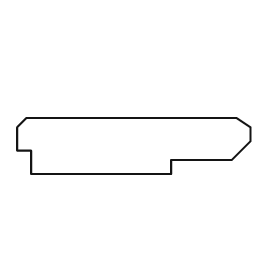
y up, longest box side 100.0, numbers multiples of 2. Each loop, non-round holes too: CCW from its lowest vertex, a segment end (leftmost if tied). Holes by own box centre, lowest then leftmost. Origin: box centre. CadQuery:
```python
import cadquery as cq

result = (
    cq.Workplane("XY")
    .moveTo(-44.0, -12.0)
    .lineTo(16.0, -12.0)
    .lineTo(16.0, -6.0)
    .lineTo(42.0, -6.0)
    .lineTo(50.0, 2.0)
    .lineTo(50.0, 8.0)
    .lineTo(44.0, 12.0)
    .lineTo(-46.0, 12.0)
    .lineTo(-50.0, 8.0)
    .lineTo(-50.0, -2.0)
    .lineTo(-44.0, -2.0)
    .close()
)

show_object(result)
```